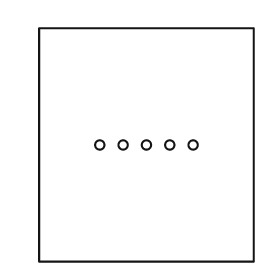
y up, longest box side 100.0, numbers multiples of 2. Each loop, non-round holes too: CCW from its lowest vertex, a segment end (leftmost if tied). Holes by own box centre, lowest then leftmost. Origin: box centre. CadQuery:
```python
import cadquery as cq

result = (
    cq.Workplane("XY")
    .moveTo(-46.0, -50.0)
    .lineTo(46.0, -50.0)
    .lineTo(46.0, 50.0)
    .lineTo(-46.0, 50.0)
    .close()
    .moveTo(-20.0, 0.0)
    .circle(2.0)
    .moveTo(-10.0, 0.0)
    .circle(2.0)
    .moveTo(0.0, 0.0)
    .circle(2.0)
    .moveTo(10.0, 0.0)
    .circle(2.0)
    .moveTo(20.0, 0.0)
    .circle(2.0)
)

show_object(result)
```